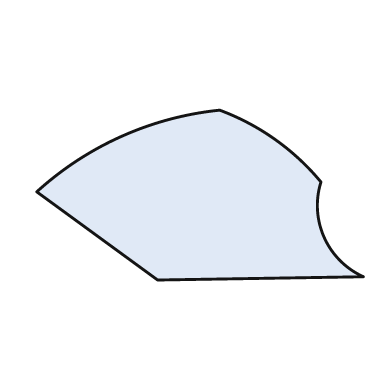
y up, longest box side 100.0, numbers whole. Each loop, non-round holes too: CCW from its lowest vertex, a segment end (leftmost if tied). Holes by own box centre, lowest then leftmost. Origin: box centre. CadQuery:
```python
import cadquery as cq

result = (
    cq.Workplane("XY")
    .moveTo(-13.0, -26.0)
    .lineTo(50.0, -25.0)
    .threePointArc((38.0, -13.0), (37.0, 4.0))
    .threePointArc((23.0, 17.0), (6.0, 26.0))
    .threePointArc((-24.0, 18.0), (-50.0, 1.0))
    .close()
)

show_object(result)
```